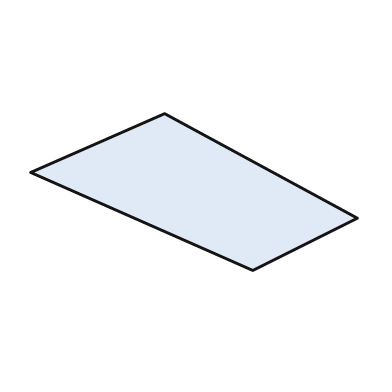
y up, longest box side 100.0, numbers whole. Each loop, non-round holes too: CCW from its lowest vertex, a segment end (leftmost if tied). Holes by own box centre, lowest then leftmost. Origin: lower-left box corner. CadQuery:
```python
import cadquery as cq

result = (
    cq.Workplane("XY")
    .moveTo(68.0, 0.0)
    .lineTo(100.0, 16.0)
    .lineTo(41.0, 48.0)
    .lineTo(0.0, 30.0)
    .close()
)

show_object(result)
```